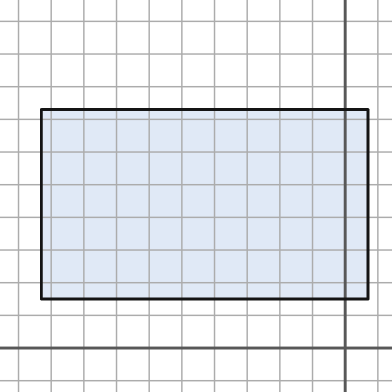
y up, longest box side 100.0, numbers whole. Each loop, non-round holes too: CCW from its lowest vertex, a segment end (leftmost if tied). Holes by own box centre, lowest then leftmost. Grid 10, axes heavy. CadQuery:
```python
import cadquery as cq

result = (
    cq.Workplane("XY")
    .moveTo(-93.0, 15.0)
    .lineTo(7.0, 15.0)
    .lineTo(7.0, 73.0)
    .lineTo(-93.0, 73.0)
    .close()
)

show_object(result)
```